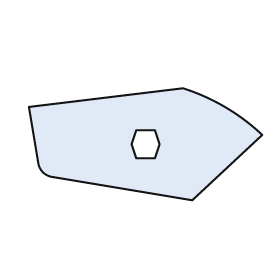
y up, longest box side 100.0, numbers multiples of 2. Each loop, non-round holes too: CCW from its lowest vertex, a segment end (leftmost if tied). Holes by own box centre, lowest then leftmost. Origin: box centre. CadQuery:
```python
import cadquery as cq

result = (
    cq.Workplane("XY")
    .moveTo(20.0, -24.0)
    .lineTo(50.0, 4.0)
    .threePointArc((34.0, 16.0), (16.0, 24.0))
    .lineTo(-50.0, 16.0)
    .lineTo(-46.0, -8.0)
    .threePointArc((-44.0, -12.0), (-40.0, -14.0))
    .close()
    .moveTo(-4.0, -6.0)
    .lineTo(4.0, -6.0)
    .lineTo(6.0, 0.0)
    .lineTo(4.0, 6.0)
    .lineTo(-4.0, 6.0)
    .lineTo(-6.0, 0.0)
    .close()
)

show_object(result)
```